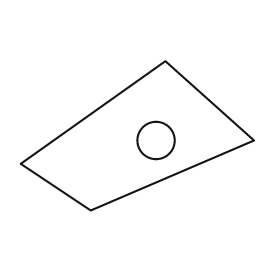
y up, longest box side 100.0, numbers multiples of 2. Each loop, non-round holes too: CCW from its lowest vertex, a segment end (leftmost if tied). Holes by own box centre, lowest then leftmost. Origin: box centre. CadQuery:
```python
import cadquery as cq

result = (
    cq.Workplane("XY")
    .moveTo(-20.0, -32.0)
    .lineTo(50.0, -2.0)
    .lineTo(12.0, 32.0)
    .lineTo(-50.0, -12.0)
    .close()
    .moveTo(8.0, -2.0)
    .circle(8.0)
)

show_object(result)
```